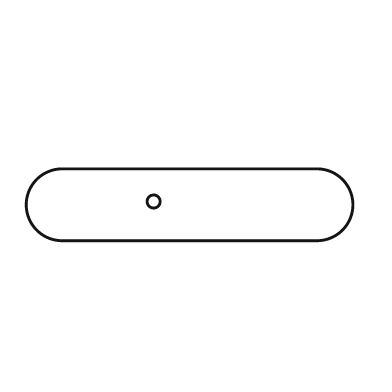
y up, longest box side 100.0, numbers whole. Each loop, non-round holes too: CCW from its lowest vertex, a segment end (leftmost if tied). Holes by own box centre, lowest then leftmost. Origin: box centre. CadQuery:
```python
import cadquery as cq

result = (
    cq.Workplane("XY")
    .moveTo(-39.0, -11.0)
    .lineTo(39.0, -11.0)
    .threePointArc((50.0, 0.0), (39.0, 11.0))
    .lineTo(-39.0, 11.0)
    .threePointArc((-50.0, 0.0), (-39.0, -11.0))
    .close()
    .moveTo(-11.0, 1.0)
    .circle(2.0)
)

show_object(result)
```